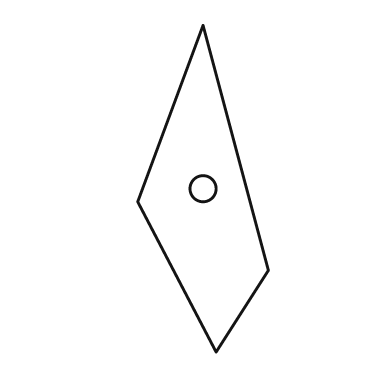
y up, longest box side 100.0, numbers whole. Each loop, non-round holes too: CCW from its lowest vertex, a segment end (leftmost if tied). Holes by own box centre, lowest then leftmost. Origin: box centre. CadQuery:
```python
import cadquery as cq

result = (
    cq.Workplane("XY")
    .moveTo(4.0, -50.0)
    .lineTo(20.0, -25.0)
    .lineTo(0.0, 50.0)
    .lineTo(-20.0, -4.0)
    .close()
    .moveTo(0.0, 0.0)
    .circle(4.0)
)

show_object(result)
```